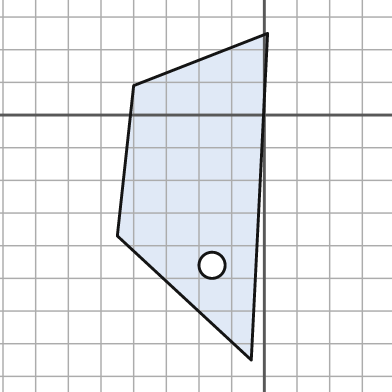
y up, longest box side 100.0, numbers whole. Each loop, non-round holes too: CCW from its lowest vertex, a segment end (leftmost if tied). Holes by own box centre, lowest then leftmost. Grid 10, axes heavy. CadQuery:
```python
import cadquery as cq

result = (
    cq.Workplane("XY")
    .moveTo(-4.0, -75.0)
    .lineTo(1.0, 25.0)
    .lineTo(-40.0, 9.0)
    .lineTo(-45.0, -37.0)
    .close()
    .moveTo(-16.0, -46.0)
    .circle(4.0)
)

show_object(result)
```